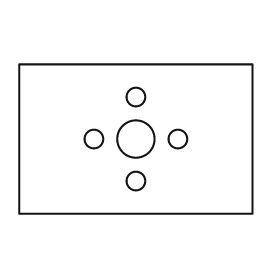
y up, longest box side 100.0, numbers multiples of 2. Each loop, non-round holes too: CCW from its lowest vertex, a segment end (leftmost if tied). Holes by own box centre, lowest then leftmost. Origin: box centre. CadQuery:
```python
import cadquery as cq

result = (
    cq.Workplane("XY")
    .moveTo(-50.0, -32.0)
    .lineTo(50.0, -32.0)
    .lineTo(50.0, 32.0)
    .lineTo(-50.0, 32.0)
    .close()
    .moveTo(0.0, -18.0)
    .circle(4.0)
    .moveTo(-18.0, 0.0)
    .circle(4.0)
    .moveTo(0.0, 0.0)
    .circle(8.0)
    .moveTo(18.0, 0.0)
    .circle(4.0)
    .moveTo(0.0, 18.0)
    .circle(4.0)
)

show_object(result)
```